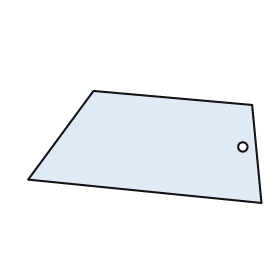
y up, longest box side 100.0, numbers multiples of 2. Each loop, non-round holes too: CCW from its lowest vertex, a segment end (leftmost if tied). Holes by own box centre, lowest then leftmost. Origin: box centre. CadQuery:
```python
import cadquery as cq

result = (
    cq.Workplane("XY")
    .moveTo(50.0, -24.0)
    .lineTo(46.0, 18.0)
    .lineTo(-22.0, 24.0)
    .lineTo(-50.0, -14.0)
    .close()
    .moveTo(42.0, 0.0)
    .circle(2.0)
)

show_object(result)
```